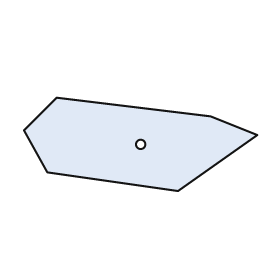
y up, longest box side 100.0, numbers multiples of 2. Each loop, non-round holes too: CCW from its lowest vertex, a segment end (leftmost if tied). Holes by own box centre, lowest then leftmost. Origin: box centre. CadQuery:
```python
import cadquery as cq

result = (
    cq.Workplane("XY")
    .moveTo(16.0, -20.0)
    .lineTo(50.0, 4.0)
    .lineTo(30.0, 12.0)
    .lineTo(-36.0, 20.0)
    .lineTo(-50.0, 6.0)
    .lineTo(-40.0, -12.0)
    .close()
    .moveTo(0.0, 0.0)
    .circle(2.0)
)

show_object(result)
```